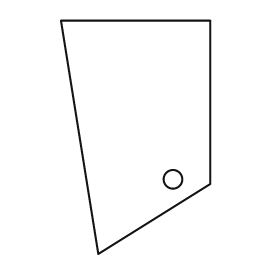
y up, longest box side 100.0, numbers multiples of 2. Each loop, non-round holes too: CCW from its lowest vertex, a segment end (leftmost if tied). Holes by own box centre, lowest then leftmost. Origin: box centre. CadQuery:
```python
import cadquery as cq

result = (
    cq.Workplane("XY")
    .moveTo(-16.0, -50.0)
    .lineTo(32.0, -20.0)
    .lineTo(32.0, 50.0)
    .lineTo(-32.0, 50.0)
    .close()
    .moveTo(16.0, -18.0)
    .circle(4.0)
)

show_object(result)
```